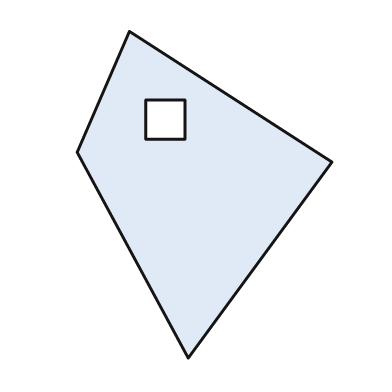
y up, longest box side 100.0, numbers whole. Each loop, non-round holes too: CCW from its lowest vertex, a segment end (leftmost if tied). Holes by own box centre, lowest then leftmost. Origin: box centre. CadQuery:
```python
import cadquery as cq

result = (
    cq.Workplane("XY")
    .moveTo(-5.0, -50.0)
    .lineTo(39.0, 10.0)
    .lineTo(-23.0, 50.0)
    .lineTo(-39.0, 13.0)
    .close()
    .moveTo(-18.0, 17.0)
    .lineTo(-6.0, 17.0)
    .lineTo(-6.0, 29.0)
    .lineTo(-18.0, 29.0)
    .close()
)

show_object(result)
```